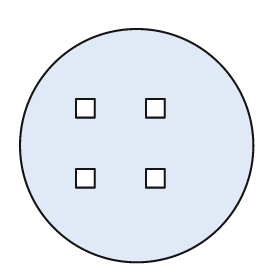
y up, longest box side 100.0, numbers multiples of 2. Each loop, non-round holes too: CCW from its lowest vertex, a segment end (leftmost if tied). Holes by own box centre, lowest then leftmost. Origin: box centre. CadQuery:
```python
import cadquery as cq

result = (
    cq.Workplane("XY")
    .moveTo(0.0, 0.0)
    .circle(50.0)
    .moveTo(-26.0, -18.0)
    .lineTo(-18.0, -18.0)
    .lineTo(-18.0, -10.0)
    .lineTo(-26.0, -10.0)
    .close()
    .moveTo(4.0, -18.0)
    .lineTo(12.0, -18.0)
    .lineTo(12.0, -10.0)
    .lineTo(4.0, -10.0)
    .close()
    .moveTo(-26.0, 12.0)
    .lineTo(-18.0, 12.0)
    .lineTo(-18.0, 20.0)
    .lineTo(-26.0, 20.0)
    .close()
    .moveTo(4.0, 12.0)
    .lineTo(12.0, 12.0)
    .lineTo(12.0, 20.0)
    .lineTo(4.0, 20.0)
    .close()
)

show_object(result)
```